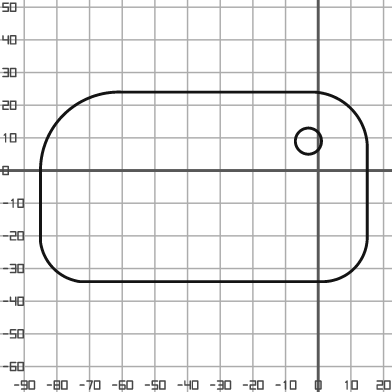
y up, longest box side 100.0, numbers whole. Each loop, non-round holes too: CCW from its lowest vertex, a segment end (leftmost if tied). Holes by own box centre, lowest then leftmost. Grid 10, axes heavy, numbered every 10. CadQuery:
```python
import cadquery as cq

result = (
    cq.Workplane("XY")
    .moveTo(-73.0, -34.0)
    .lineTo(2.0, -34.0)
    .threePointArc((11.0, -30.0), (15.0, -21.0))
    .lineTo(15.0, 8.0)
    .threePointArc((10.0, 19.0), (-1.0, 24.0))
    .lineTo(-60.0, 24.0)
    .threePointArc((-78.0, 17.0), (-85.0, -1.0))
    .lineTo(-85.0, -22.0)
    .threePointArc((-81.0, -30.0), (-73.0, -34.0))
    .close()
    .moveTo(-3.0, 9.0)
    .circle(4.0)
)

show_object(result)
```